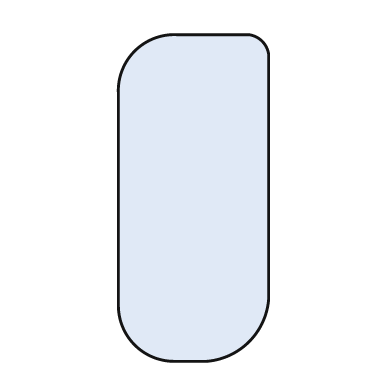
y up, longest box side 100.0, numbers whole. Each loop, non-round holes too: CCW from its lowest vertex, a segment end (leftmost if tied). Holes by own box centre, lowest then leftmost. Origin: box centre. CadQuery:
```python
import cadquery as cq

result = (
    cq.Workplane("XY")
    .moveTo(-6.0, -50.0)
    .lineTo(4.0, -50.0)
    .threePointArc((17.0, -44.0), (23.0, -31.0))
    .lineTo(23.0, 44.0)
    .threePointArc((21.0, 48.0), (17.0, 50.0))
    .lineTo(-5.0, 50.0)
    .threePointArc((-18.0, 45.0), (-23.0, 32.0))
    .lineTo(-23.0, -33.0)
    .threePointArc((-18.0, -45.0), (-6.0, -50.0))
    .close()
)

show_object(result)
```